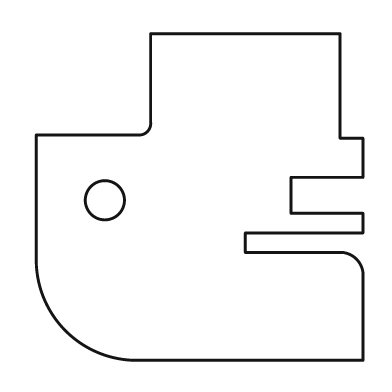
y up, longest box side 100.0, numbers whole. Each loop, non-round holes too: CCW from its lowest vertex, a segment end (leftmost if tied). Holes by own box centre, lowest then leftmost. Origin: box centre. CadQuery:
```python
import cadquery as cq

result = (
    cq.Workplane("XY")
    .moveTo(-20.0, -50.0)
    .lineTo(50.0, -50.0)
    .lineTo(50.0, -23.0)
    .threePointArc((48.0, -19.0), (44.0, -17.0))
    .lineTo(14.0, -17.0)
    .lineTo(14.0, -11.0)
    .lineTo(50.0, -11.0)
    .lineTo(50.0, -5.0)
    .lineTo(28.0, -5.0)
    .lineTo(28.0, 6.0)
    .lineTo(50.0, 6.0)
    .lineTo(50.0, 18.0)
    .lineTo(43.0, 18.0)
    .lineTo(43.0, 50.0)
    .lineTo(-15.0, 50.0)
    .lineTo(-15.0, 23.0)
    .threePointArc((-16.0, 20.0), (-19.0, 19.0))
    .lineTo(-50.0, 19.0)
    .lineTo(-50.0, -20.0)
    .threePointArc((-41.0, -41.0), (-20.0, -50.0))
    .close()
    .moveTo(-29.0, -1.0)
    .circle(6.0)
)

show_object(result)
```